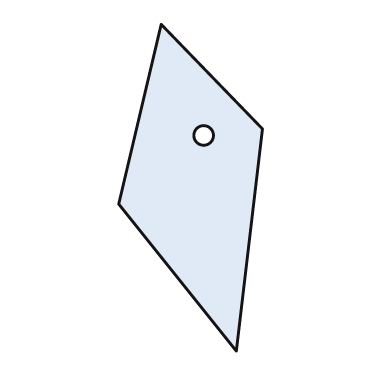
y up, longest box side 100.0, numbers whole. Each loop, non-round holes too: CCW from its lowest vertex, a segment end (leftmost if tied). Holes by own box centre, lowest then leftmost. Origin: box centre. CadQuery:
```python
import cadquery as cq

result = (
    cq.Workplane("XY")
    .moveTo(14.0, -50.0)
    .lineTo(22.0, 18.0)
    .lineTo(-9.0, 50.0)
    .lineTo(-22.0, -5.0)
    .close()
    .moveTo(4.0, 16.0)
    .circle(3.0)
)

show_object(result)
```